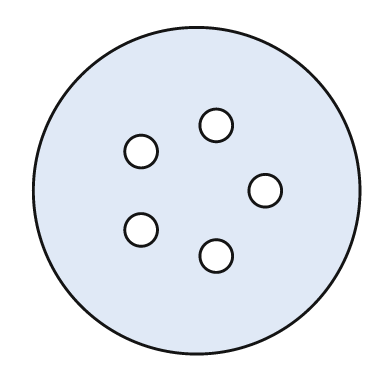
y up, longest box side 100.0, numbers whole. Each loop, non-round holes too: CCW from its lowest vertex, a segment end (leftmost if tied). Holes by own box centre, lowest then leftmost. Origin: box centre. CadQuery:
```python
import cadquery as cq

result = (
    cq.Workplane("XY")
    .moveTo(0.0, 0.0)
    .circle(50.0)
    .moveTo(6.0, -20.0)
    .circle(5.0)
    .moveTo(-17.0, -12.0)
    .circle(5.0)
    .moveTo(21.0, 0.0)
    .circle(5.0)
    .moveTo(-17.0, 12.0)
    .circle(5.0)
    .moveTo(6.0, 20.0)
    .circle(5.0)
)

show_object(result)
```